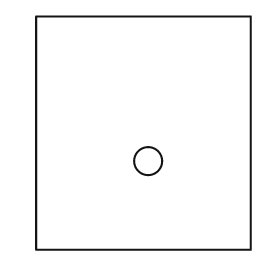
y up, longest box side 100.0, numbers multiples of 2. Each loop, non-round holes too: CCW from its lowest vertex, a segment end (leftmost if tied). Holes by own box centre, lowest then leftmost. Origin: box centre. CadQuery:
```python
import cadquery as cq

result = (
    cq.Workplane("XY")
    .moveTo(-46.0, -50.0)
    .lineTo(46.0, -50.0)
    .lineTo(46.0, 50.0)
    .lineTo(-46.0, 50.0)
    .close()
    .moveTo(2.0, -12.0)
    .circle(6.0)
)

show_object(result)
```